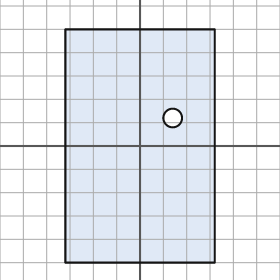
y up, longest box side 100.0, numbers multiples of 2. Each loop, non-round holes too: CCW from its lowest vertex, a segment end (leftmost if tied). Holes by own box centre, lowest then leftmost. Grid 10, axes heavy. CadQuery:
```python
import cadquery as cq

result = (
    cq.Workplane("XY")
    .moveTo(-32.0, -50.0)
    .lineTo(32.0, -50.0)
    .lineTo(32.0, 50.0)
    .lineTo(-32.0, 50.0)
    .close()
    .moveTo(14.0, 12.0)
    .circle(4.0)
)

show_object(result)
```